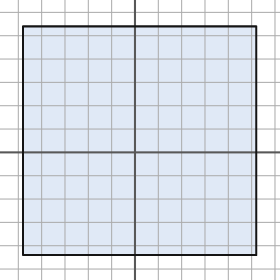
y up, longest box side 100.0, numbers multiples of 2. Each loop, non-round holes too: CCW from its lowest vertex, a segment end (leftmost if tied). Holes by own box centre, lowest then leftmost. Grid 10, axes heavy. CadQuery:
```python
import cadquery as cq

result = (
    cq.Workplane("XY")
    .moveTo(-48.0, -44.0)
    .lineTo(52.0, -44.0)
    .lineTo(52.0, 54.0)
    .lineTo(-48.0, 54.0)
    .close()
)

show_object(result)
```